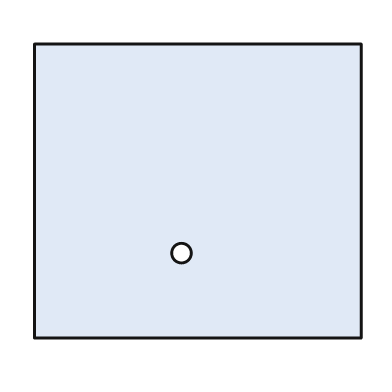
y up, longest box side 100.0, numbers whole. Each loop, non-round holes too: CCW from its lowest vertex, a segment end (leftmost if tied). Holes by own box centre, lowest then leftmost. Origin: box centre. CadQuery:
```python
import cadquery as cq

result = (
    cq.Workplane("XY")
    .moveTo(-50.0, -45.0)
    .lineTo(50.0, -45.0)
    .lineTo(50.0, 45.0)
    .lineTo(-50.0, 45.0)
    .close()
    .moveTo(-5.0, -19.0)
    .circle(3.0)
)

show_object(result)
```